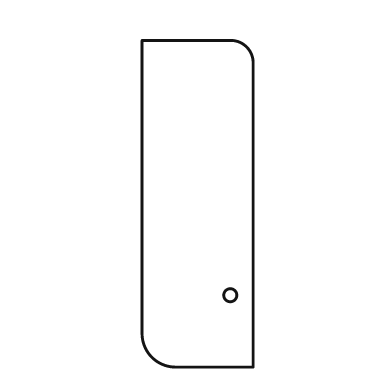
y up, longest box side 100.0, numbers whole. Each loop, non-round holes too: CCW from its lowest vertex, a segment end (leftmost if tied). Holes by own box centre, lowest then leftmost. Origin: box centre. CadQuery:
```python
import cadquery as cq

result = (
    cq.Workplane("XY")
    .moveTo(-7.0, -50.0)
    .lineTo(17.0, -50.0)
    .lineTo(17.0, 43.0)
    .threePointArc((15.0, 48.0), (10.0, 50.0))
    .lineTo(-17.0, 50.0)
    .lineTo(-17.0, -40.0)
    .threePointArc((-14.0, -47.0), (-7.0, -50.0))
    .close()
    .moveTo(10.0, -28.0)
    .circle(2.0)
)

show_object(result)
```